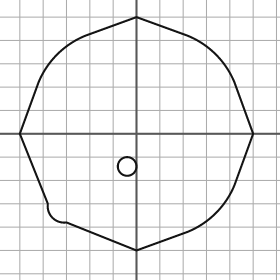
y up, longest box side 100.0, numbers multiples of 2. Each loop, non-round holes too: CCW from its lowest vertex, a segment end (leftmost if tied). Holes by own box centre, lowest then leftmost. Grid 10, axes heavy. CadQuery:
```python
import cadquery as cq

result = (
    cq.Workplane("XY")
    .moveTo(0.0, -50.0)
    .lineTo(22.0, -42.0)
    .threePointArc((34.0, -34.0), (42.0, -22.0))
    .lineTo(50.0, 0.0)
    .lineTo(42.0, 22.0)
    .threePointArc((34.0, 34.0), (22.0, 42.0))
    .lineTo(0.0, 50.0)
    .lineTo(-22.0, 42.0)
    .threePointArc((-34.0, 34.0), (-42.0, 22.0))
    .lineTo(-50.0, 0.0)
    .lineTo(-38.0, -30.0)
    .threePointArc((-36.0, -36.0), (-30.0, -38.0))
    .close()
    .moveTo(-4.0, -14.0)
    .circle(4.0)
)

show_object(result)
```